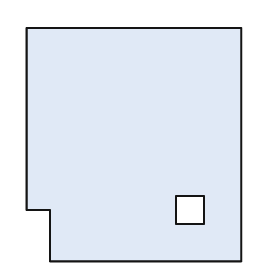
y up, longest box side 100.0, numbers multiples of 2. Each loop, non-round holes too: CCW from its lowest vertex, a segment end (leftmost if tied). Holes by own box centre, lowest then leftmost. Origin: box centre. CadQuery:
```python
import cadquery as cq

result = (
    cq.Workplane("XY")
    .moveTo(-36.0, -50.0)
    .lineTo(46.0, -50.0)
    .lineTo(46.0, 50.0)
    .lineTo(-46.0, 50.0)
    .lineTo(-46.0, -28.0)
    .lineTo(-36.0, -28.0)
    .close()
    .moveTo(18.0, -34.0)
    .lineTo(30.0, -34.0)
    .lineTo(30.0, -22.0)
    .lineTo(18.0, -22.0)
    .close()
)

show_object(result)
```